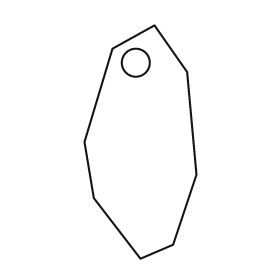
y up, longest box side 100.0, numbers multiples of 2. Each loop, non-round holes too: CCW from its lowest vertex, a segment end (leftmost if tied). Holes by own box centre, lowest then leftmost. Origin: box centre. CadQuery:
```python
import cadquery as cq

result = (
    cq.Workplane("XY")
    .moveTo(0.0, -50.0)
    .lineTo(14.0, -44.0)
    .lineTo(24.0, -14.0)
    .lineTo(20.0, 30.0)
    .lineTo(6.0, 50.0)
    .lineTo(-12.0, 40.0)
    .lineTo(-24.0, 0.0)
    .lineTo(-20.0, -24.0)
    .close()
    .moveTo(-2.0, 34.0)
    .circle(6.0)
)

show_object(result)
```